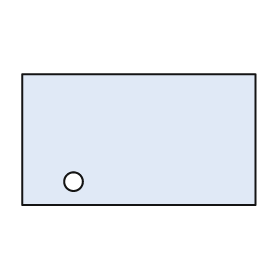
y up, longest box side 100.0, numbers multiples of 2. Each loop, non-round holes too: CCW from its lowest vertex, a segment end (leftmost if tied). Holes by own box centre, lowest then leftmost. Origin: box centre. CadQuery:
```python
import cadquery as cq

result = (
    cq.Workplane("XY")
    .moveTo(-50.0, -28.0)
    .lineTo(50.0, -28.0)
    .lineTo(50.0, 28.0)
    .lineTo(-50.0, 28.0)
    .close()
    .moveTo(-28.0, -18.0)
    .circle(4.0)
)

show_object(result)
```